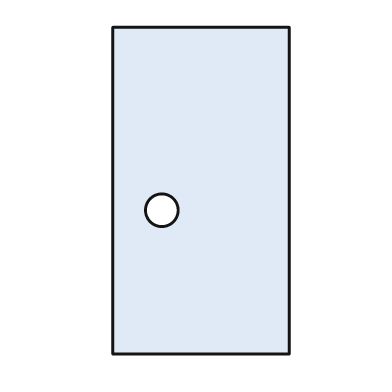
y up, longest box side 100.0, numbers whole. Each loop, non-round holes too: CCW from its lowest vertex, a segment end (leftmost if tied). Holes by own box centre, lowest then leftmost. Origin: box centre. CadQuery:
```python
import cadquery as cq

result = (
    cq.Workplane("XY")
    .moveTo(-27.0, -50.0)
    .lineTo(27.0, -50.0)
    .lineTo(27.0, 50.0)
    .lineTo(-27.0, 50.0)
    .close()
    .moveTo(-12.0, -6.0)
    .circle(5.0)
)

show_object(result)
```